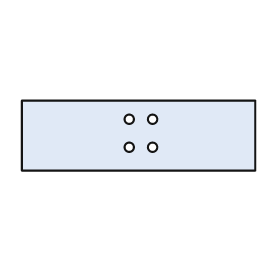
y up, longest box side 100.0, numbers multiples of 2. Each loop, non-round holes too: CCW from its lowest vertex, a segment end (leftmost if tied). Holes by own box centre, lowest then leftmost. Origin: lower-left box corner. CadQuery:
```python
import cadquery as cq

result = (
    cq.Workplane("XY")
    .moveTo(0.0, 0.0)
    .lineTo(100.0, 0.0)
    .lineTo(100.0, 30.0)
    .lineTo(0.0, 30.0)
    .close()
    .moveTo(46.0, 10.0)
    .circle(2.0)
    .moveTo(56.0, 10.0)
    .circle(2.0)
    .moveTo(46.0, 22.0)
    .circle(2.0)
    .moveTo(56.0, 22.0)
    .circle(2.0)
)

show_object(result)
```